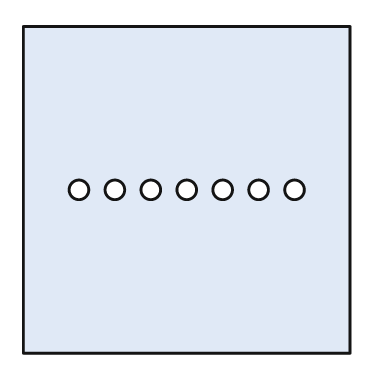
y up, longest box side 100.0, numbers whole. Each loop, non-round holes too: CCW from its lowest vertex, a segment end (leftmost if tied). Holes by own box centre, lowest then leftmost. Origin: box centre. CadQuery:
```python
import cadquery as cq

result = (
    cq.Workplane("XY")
    .moveTo(-50.0, -50.0)
    .lineTo(50.0, -50.0)
    .lineTo(50.0, 50.0)
    .lineTo(-50.0, 50.0)
    .close()
    .moveTo(-33.0, 0.0)
    .circle(3.0)
    .moveTo(-22.0, 0.0)
    .circle(3.0)
    .moveTo(-11.0, 0.0)
    .circle(3.0)
    .moveTo(0.0, 0.0)
    .circle(3.0)
    .moveTo(11.0, 0.0)
    .circle(3.0)
    .moveTo(22.0, 0.0)
    .circle(3.0)
    .moveTo(33.0, 0.0)
    .circle(3.0)
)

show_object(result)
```